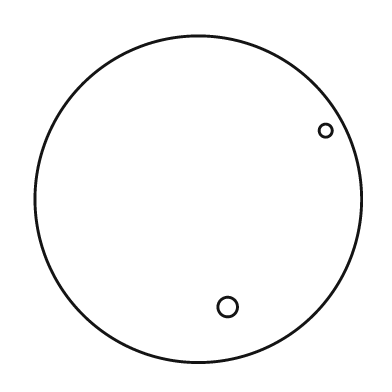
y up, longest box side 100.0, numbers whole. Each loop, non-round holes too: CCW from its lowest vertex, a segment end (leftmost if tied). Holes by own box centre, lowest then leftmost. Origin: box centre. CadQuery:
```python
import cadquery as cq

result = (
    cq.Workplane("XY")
    .moveTo(0.0, 0.0)
    .circle(50.0)
    .moveTo(9.0, -33.0)
    .circle(3.0)
    .moveTo(39.0, 21.0)
    .circle(2.0)
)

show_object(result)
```